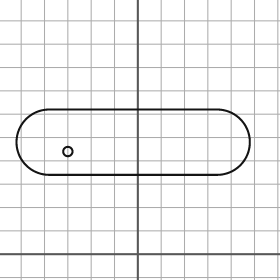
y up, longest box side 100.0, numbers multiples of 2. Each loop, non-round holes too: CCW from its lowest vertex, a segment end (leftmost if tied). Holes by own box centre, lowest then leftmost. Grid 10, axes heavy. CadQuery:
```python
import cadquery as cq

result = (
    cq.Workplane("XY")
    .moveTo(-38.0, 34.0)
    .lineTo(34.0, 34.0)
    .threePointArc((48.0, 48.0), (34.0, 62.0))
    .lineTo(-38.0, 62.0)
    .threePointArc((-52.0, 48.0), (-38.0, 34.0))
    .close()
    .moveTo(-30.0, 44.0)
    .circle(2.0)
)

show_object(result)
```